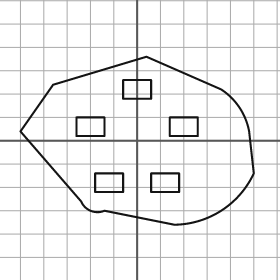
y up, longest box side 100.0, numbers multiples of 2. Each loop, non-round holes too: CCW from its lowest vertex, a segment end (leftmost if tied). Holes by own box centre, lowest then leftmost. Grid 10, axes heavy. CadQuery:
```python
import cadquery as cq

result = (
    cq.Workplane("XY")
    .moveTo(16.0, -36.0)
    .threePointArc((36.0, -30.0), (50.0, -14.0))
    .lineTo(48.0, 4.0)
    .threePointArc((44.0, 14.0), (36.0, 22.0))
    .lineTo(4.0, 36.0)
    .lineTo(-36.0, 24.0)
    .lineTo(-50.0, 4.0)
    .lineTo(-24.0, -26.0)
    .threePointArc((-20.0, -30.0), (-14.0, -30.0))
    .close()
    .moveTo(-18.0, -22.0)
    .lineTo(-6.0, -22.0)
    .lineTo(-6.0, -14.0)
    .lineTo(-18.0, -14.0)
    .close()
    .moveTo(6.0, -22.0)
    .lineTo(18.0, -22.0)
    .lineTo(18.0, -14.0)
    .lineTo(6.0, -14.0)
    .close()
    .moveTo(-26.0, 2.0)
    .lineTo(-14.0, 2.0)
    .lineTo(-14.0, 10.0)
    .lineTo(-26.0, 10.0)
    .close()
    .moveTo(14.0, 2.0)
    .lineTo(26.0, 2.0)
    .lineTo(26.0, 10.0)
    .lineTo(14.0, 10.0)
    .close()
    .moveTo(-6.0, 18.0)
    .lineTo(6.0, 18.0)
    .lineTo(6.0, 26.0)
    .lineTo(-6.0, 26.0)
    .close()
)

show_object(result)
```